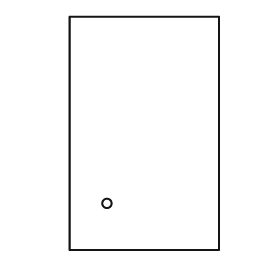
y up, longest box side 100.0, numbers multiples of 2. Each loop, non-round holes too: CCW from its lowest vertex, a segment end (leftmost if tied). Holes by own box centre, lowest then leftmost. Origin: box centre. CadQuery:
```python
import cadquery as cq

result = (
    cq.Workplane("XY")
    .moveTo(-32.0, -50.0)
    .lineTo(32.0, -50.0)
    .lineTo(32.0, 50.0)
    .lineTo(-32.0, 50.0)
    .close()
    .moveTo(-16.0, -30.0)
    .circle(2.0)
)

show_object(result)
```